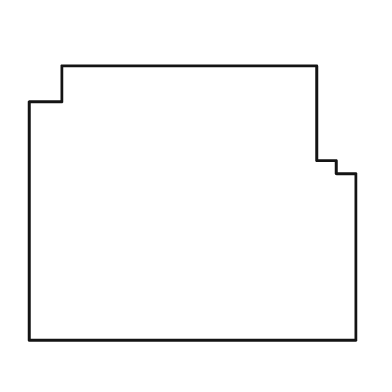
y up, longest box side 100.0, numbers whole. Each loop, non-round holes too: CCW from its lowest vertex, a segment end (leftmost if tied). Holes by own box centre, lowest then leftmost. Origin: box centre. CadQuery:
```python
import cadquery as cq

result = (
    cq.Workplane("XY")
    .moveTo(-50.0, -42.0)
    .lineTo(50.0, -42.0)
    .lineTo(50.0, 9.0)
    .lineTo(44.0, 9.0)
    .lineTo(44.0, 13.0)
    .lineTo(38.0, 13.0)
    .lineTo(38.0, 42.0)
    .lineTo(-40.0, 42.0)
    .lineTo(-40.0, 31.0)
    .lineTo(-50.0, 31.0)
    .close()
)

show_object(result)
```